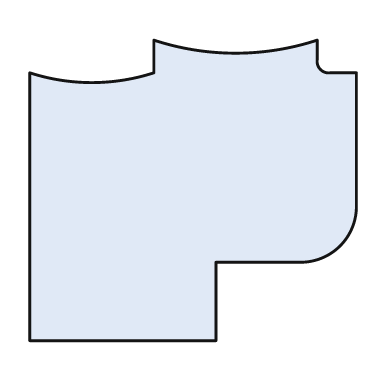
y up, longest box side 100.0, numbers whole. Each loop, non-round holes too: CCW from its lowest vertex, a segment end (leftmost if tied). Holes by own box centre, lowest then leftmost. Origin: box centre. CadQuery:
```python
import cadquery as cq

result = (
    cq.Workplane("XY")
    .moveTo(-50.0, -46.0)
    .lineTo(7.0, -46.0)
    .lineTo(7.0, -22.0)
    .lineTo(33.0, -22.0)
    .threePointArc((45.0, -17.0), (50.0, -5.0))
    .lineTo(50.0, 36.0)
    .lineTo(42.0, 36.0)
    .threePointArc((39.0, 37.0), (38.0, 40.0))
    .lineTo(38.0, 46.0)
    .threePointArc((13.0, 42.0), (-12.0, 46.0))
    .lineTo(-12.0, 36.0)
    .threePointArc((-31.0, 33.0), (-50.0, 36.0))
    .close()
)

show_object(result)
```